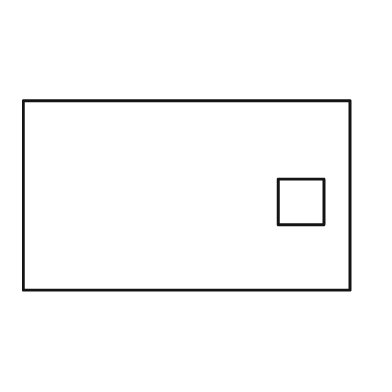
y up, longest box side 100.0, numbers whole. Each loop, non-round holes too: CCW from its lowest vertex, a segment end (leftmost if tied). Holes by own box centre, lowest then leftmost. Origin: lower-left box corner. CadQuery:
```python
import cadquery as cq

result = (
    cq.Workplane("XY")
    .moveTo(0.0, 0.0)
    .lineTo(100.0, 0.0)
    .lineTo(100.0, 58.0)
    .lineTo(0.0, 58.0)
    .close()
    .moveTo(78.0, 20.0)
    .lineTo(92.0, 20.0)
    .lineTo(92.0, 34.0)
    .lineTo(78.0, 34.0)
    .close()
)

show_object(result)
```